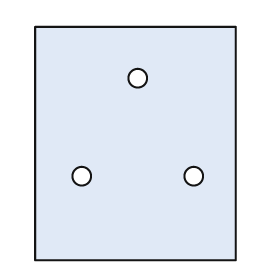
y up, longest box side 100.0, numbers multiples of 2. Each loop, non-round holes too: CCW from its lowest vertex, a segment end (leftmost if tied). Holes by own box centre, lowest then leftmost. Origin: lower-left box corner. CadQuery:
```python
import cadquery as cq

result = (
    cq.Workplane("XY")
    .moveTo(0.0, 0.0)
    .lineTo(86.0, 0.0)
    .lineTo(86.0, 100.0)
    .lineTo(0.0, 100.0)
    .close()
    .moveTo(20.0, 36.0)
    .circle(4.0)
    .moveTo(68.0, 36.0)
    .circle(4.0)
    .moveTo(44.0, 78.0)
    .circle(4.0)
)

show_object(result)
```